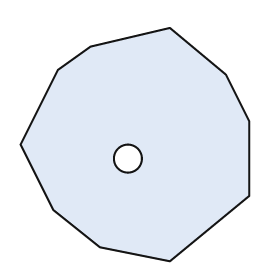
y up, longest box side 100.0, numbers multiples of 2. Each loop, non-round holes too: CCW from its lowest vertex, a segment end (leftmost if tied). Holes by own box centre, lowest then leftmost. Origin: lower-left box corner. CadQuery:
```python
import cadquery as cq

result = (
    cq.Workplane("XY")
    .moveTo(64.0, 0.0)
    .lineTo(98.0, 28.0)
    .lineTo(98.0, 60.0)
    .lineTo(88.0, 80.0)
    .lineTo(64.0, 100.0)
    .lineTo(30.0, 92.0)
    .lineTo(16.0, 82.0)
    .lineTo(0.0, 50.0)
    .lineTo(14.0, 22.0)
    .lineTo(34.0, 6.0)
    .close()
    .moveTo(46.0, 44.0)
    .circle(6.0)
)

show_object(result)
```